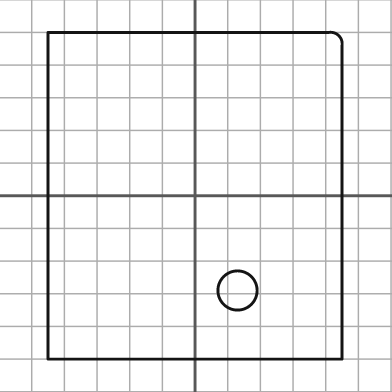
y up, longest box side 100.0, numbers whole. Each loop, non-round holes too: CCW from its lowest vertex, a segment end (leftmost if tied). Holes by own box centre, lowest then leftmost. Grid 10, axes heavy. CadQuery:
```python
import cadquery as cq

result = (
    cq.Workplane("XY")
    .moveTo(-45.0, -50.0)
    .lineTo(45.0, -50.0)
    .lineTo(45.0, 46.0)
    .threePointArc((44.0, 49.0), (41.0, 50.0))
    .lineTo(-45.0, 50.0)
    .close()
    .moveTo(13.0, -29.0)
    .circle(6.0)
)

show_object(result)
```